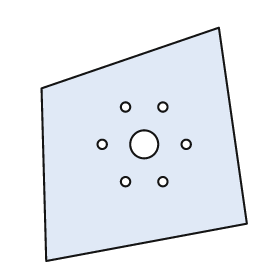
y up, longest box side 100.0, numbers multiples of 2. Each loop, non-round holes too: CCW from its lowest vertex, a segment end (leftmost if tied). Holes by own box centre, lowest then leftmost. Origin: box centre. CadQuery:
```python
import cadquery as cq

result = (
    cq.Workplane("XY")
    .moveTo(-42.0, -50.0)
    .lineTo(44.0, -34.0)
    .lineTo(32.0, 50.0)
    .lineTo(-44.0, 24.0)
    .close()
    .moveTo(-8.0, -16.0)
    .circle(2.0)
    .moveTo(8.0, -16.0)
    .circle(2.0)
    .moveTo(-18.0, 0.0)
    .circle(2.0)
    .moveTo(0.0, 0.0)
    .circle(6.0)
    .moveTo(18.0, 0.0)
    .circle(2.0)
    .moveTo(-8.0, 16.0)
    .circle(2.0)
    .moveTo(8.0, 16.0)
    .circle(2.0)
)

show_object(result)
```